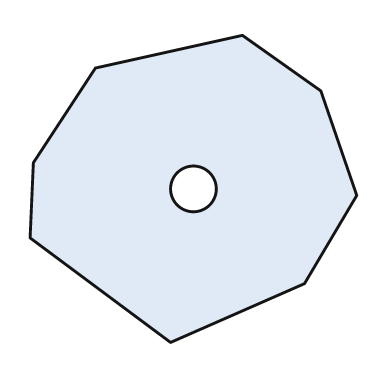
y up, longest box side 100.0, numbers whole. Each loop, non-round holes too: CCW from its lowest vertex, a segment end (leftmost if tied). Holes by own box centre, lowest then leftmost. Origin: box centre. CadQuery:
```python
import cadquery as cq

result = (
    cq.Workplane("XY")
    .moveTo(-7.0, -47.0)
    .lineTo(34.0, -29.0)
    .lineTo(50.0, -2.0)
    .lineTo(39.0, 30.0)
    .lineTo(15.0, 47.0)
    .lineTo(-30.0, 37.0)
    .lineTo(-49.0, 8.0)
    .lineTo(-50.0, -15.0)
    .close()
    .moveTo(0.0, 0.0)
    .circle(7.0)
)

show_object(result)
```